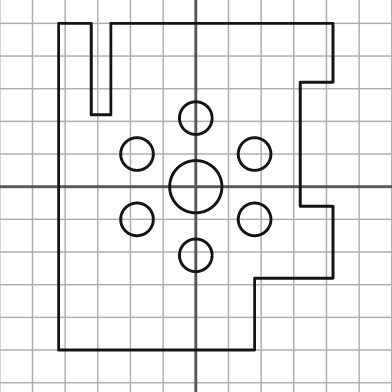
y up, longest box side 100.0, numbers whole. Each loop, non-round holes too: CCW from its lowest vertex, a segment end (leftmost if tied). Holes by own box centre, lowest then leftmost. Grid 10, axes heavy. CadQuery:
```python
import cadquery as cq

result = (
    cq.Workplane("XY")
    .moveTo(-42.0, -50.0)
    .lineTo(18.0, -50.0)
    .lineTo(18.0, -28.0)
    .lineTo(42.0, -28.0)
    .lineTo(42.0, -6.0)
    .lineTo(32.0, -6.0)
    .lineTo(32.0, 32.0)
    .lineTo(42.0, 32.0)
    .lineTo(42.0, 50.0)
    .lineTo(-26.0, 50.0)
    .lineTo(-26.0, 22.0)
    .lineTo(-32.0, 22.0)
    .lineTo(-32.0, 50.0)
    .lineTo(-42.0, 50.0)
    .close()
    .moveTo(0.0, -21.0)
    .circle(5.0)
    .moveTo(-18.0, -10.0)
    .circle(5.0)
    .moveTo(18.0, -10.0)
    .circle(5.0)
    .moveTo(0.0, 0.0)
    .circle(8.0)
    .moveTo(-18.0, 10.0)
    .circle(5.0)
    .moveTo(18.0, 10.0)
    .circle(5.0)
    .moveTo(0.0, 21.0)
    .circle(5.0)
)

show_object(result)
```